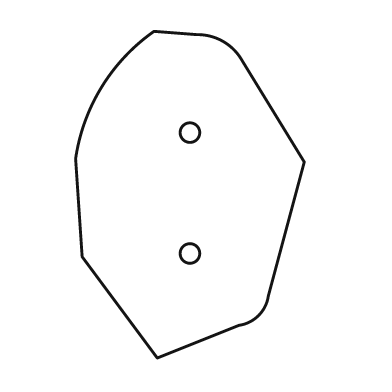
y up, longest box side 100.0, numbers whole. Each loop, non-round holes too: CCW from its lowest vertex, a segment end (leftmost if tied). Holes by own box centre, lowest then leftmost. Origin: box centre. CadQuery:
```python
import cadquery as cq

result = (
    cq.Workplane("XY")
    .moveTo(-10.0, -50.0)
    .lineTo(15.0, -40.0)
    .threePointArc((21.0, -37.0), (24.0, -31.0))
    .lineTo(35.0, 10.0)
    .lineTo(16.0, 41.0)
    .threePointArc((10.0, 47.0), (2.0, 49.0))
    .lineTo(-11.0, 50.0)
    .threePointArc((-27.0, 33.0), (-35.0, 11.0))
    .lineTo(-33.0, -19.0)
    .close()
    .moveTo(0.0, -18.0)
    .circle(3.0)
    .moveTo(0.0, 19.0)
    .circle(3.0)
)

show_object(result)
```